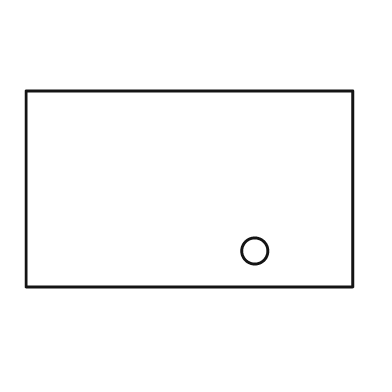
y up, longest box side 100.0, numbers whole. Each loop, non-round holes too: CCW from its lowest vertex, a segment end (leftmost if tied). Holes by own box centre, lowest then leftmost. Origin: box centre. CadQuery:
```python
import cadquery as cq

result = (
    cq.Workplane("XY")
    .moveTo(-50.0, -30.0)
    .lineTo(50.0, -30.0)
    .lineTo(50.0, 30.0)
    .lineTo(-50.0, 30.0)
    .close()
    .moveTo(20.0, -19.0)
    .circle(4.0)
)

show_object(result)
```